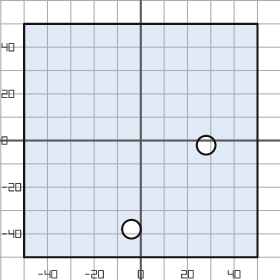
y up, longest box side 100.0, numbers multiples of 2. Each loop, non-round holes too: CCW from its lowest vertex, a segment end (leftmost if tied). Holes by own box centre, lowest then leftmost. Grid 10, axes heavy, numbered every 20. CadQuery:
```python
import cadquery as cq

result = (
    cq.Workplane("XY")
    .moveTo(-50.0, -50.0)
    .lineTo(50.0, -50.0)
    .lineTo(50.0, 50.0)
    .lineTo(-50.0, 50.0)
    .close()
    .moveTo(-4.0, -38.0)
    .circle(4.0)
    .moveTo(28.0, -2.0)
    .circle(4.0)
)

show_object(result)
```